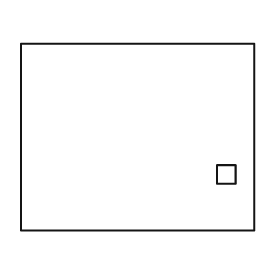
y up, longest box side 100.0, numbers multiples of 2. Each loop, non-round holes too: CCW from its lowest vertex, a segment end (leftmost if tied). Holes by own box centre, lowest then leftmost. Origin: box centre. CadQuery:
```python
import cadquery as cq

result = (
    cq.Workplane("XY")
    .moveTo(-50.0, -40.0)
    .lineTo(50.0, -40.0)
    .lineTo(50.0, 40.0)
    .lineTo(-50.0, 40.0)
    .close()
    .moveTo(34.0, -20.0)
    .lineTo(42.0, -20.0)
    .lineTo(42.0, -12.0)
    .lineTo(34.0, -12.0)
    .close()
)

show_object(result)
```